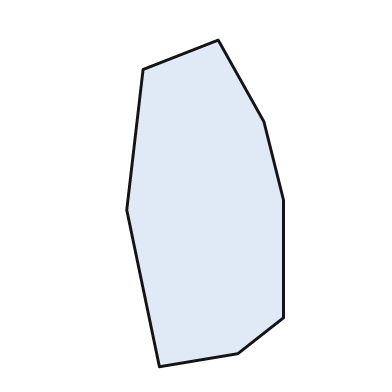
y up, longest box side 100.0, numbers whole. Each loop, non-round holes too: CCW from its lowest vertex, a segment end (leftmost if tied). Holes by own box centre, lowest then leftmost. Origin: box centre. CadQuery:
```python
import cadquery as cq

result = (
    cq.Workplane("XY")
    .moveTo(-14.0, -50.0)
    .lineTo(10.0, -46.0)
    .lineTo(24.0, -35.0)
    .lineTo(24.0, 1.0)
    .lineTo(18.0, 25.0)
    .lineTo(4.0, 50.0)
    .lineTo(-19.0, 41.0)
    .lineTo(-24.0, -2.0)
    .close()
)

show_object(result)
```